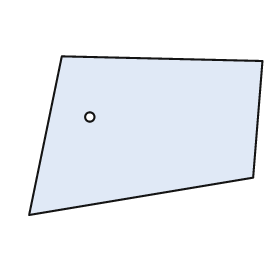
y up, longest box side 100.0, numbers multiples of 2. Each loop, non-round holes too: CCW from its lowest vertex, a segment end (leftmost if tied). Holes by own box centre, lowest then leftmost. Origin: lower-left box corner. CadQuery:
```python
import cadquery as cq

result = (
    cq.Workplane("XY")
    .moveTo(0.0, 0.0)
    .lineTo(96.0, 16.0)
    .lineTo(100.0, 66.0)
    .lineTo(14.0, 68.0)
    .close()
    .moveTo(26.0, 42.0)
    .circle(2.0)
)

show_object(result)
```